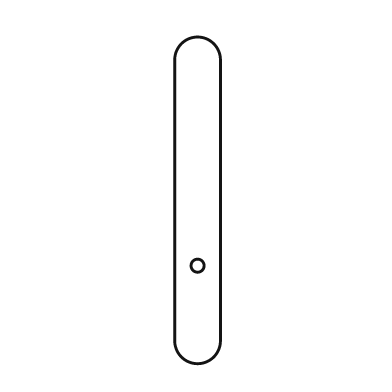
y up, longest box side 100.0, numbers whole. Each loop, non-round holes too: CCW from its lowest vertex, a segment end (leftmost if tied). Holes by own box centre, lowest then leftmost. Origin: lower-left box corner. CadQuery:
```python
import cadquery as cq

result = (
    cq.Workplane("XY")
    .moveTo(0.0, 7.0)
    .threePointArc((7.0, 0.0), (14.0, 7.0))
    .lineTo(14.0, 93.0)
    .threePointArc((7.0, 100.0), (0.0, 93.0))
    .close()
    .moveTo(7.0, 30.0)
    .circle(2.0)
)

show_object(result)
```